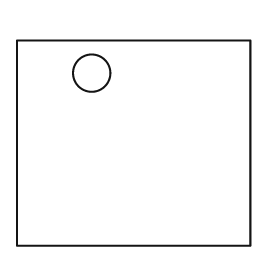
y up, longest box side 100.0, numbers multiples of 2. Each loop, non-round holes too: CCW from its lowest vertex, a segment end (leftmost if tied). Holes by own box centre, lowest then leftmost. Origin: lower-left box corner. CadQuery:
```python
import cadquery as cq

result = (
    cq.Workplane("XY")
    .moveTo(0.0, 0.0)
    .lineTo(100.0, 0.0)
    .lineTo(100.0, 88.0)
    .lineTo(0.0, 88.0)
    .close()
    .moveTo(32.0, 74.0)
    .circle(8.0)
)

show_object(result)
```